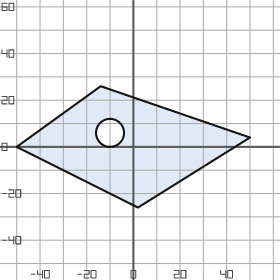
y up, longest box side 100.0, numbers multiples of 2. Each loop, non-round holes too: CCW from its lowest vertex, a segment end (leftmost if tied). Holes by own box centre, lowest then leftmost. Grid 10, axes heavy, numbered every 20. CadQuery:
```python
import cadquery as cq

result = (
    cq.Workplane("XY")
    .moveTo(2.0, -26.0)
    .lineTo(50.0, 4.0)
    .lineTo(-14.0, 26.0)
    .lineTo(-50.0, 0.0)
    .close()
    .moveTo(-10.0, 6.0)
    .circle(6.0)
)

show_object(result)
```